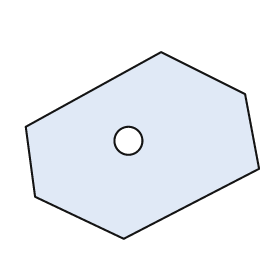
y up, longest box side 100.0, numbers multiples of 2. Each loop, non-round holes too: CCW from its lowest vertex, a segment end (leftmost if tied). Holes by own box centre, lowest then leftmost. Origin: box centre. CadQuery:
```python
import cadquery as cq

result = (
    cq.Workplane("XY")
    .moveTo(-8.0, -40.0)
    .lineTo(50.0, -10.0)
    .lineTo(44.0, 22.0)
    .lineTo(8.0, 40.0)
    .lineTo(-50.0, 8.0)
    .lineTo(-46.0, -22.0)
    .close()
    .moveTo(-6.0, 2.0)
    .circle(6.0)
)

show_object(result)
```